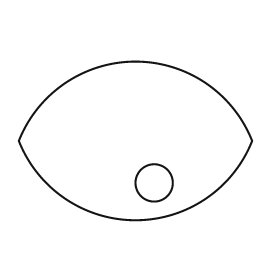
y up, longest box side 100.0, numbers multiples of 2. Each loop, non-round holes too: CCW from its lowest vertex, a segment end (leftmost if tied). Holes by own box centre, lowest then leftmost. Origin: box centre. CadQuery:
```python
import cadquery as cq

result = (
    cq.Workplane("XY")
    .moveTo(-50.0, 0.0)
    .threePointArc((0.0, -34.0), (50.0, 0.0))
    .threePointArc((0.0, 34.0), (-50.0, 0.0))
    .close()
    .moveTo(8.0, -18.0)
    .circle(8.0)
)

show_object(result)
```